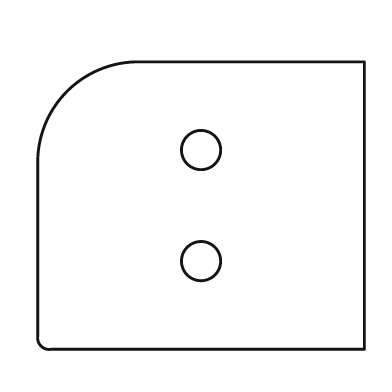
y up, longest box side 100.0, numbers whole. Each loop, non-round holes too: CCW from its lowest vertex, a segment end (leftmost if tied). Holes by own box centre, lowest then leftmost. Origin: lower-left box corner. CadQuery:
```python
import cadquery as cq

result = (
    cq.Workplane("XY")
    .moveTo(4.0, 0.0)
    .lineTo(100.0, 0.0)
    .lineTo(100.0, 88.0)
    .lineTo(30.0, 88.0)
    .threePointArc((9.0, 79.0), (0.0, 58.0))
    .lineTo(0.0, 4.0)
    .threePointArc((1.0, 1.0), (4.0, 0.0))
    .close()
    .moveTo(50.0, 27.0)
    .circle(6.0)
    .moveTo(50.0, 61.0)
    .circle(6.0)
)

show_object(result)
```